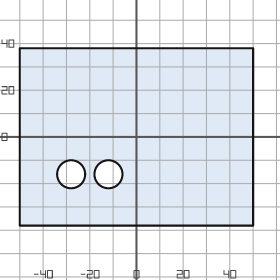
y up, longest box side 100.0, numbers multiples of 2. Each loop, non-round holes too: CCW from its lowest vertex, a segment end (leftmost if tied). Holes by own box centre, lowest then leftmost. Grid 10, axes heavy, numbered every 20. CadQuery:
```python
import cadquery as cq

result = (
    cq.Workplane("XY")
    .moveTo(-50.0, -38.0)
    .lineTo(50.0, -38.0)
    .lineTo(50.0, 38.0)
    .lineTo(-50.0, 38.0)
    .close()
    .moveTo(-28.0, -16.0)
    .circle(6.0)
    .moveTo(-12.0, -16.0)
    .circle(6.0)
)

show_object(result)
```